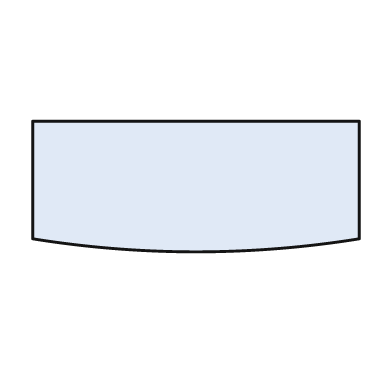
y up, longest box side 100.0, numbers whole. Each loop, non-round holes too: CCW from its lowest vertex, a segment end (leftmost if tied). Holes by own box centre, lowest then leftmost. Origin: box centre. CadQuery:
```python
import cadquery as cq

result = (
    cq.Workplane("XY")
    .moveTo(-50.0, -16.0)
    .threePointArc((0.0, -20.0), (50.0, -16.0))
    .lineTo(50.0, 20.0)
    .lineTo(-50.0, 20.0)
    .close()
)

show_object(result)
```